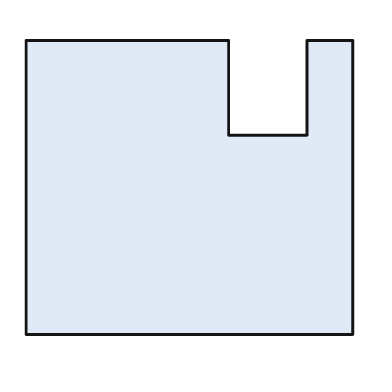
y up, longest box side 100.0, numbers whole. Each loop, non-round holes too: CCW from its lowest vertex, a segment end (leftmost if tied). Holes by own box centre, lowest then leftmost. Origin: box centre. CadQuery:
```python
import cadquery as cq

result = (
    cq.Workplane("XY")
    .moveTo(-50.0, -45.0)
    .lineTo(50.0, -45.0)
    .lineTo(50.0, 45.0)
    .lineTo(36.0, 45.0)
    .lineTo(36.0, 16.0)
    .lineTo(12.0, 16.0)
    .lineTo(12.0, 45.0)
    .lineTo(-50.0, 45.0)
    .close()
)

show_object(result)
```